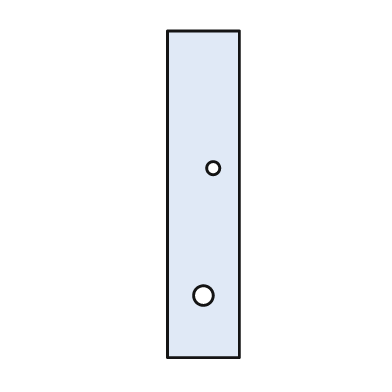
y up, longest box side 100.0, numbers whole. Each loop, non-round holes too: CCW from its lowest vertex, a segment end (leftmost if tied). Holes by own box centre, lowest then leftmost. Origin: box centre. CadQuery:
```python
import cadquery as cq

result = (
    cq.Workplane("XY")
    .moveTo(-11.0, -50.0)
    .lineTo(11.0, -50.0)
    .lineTo(11.0, 50.0)
    .lineTo(-11.0, 50.0)
    .close()
    .moveTo(0.0, -31.0)
    .circle(3.0)
    .moveTo(3.0, 8.0)
    .circle(2.0)
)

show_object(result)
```